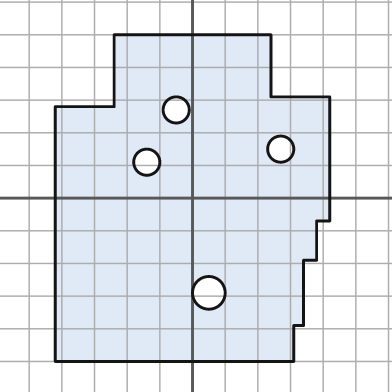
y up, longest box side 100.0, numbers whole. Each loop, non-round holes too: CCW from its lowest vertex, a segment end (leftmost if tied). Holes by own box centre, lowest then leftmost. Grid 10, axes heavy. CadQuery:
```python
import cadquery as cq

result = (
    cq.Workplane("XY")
    .moveTo(-42.0, -50.0)
    .lineTo(31.0, -50.0)
    .lineTo(31.0, -39.0)
    .lineTo(34.0, -39.0)
    .lineTo(34.0, -19.0)
    .lineTo(38.0, -19.0)
    .lineTo(38.0, -7.0)
    .lineTo(42.0, -7.0)
    .lineTo(42.0, 31.0)
    .lineTo(24.0, 31.0)
    .lineTo(24.0, 50.0)
    .lineTo(-24.0, 50.0)
    .lineTo(-24.0, 28.0)
    .lineTo(-42.0, 28.0)
    .close()
    .moveTo(5.0, -29.0)
    .circle(5.0)
    .moveTo(-14.0, 11.0)
    .circle(4.0)
    .moveTo(27.0, 15.0)
    .circle(4.0)
    .moveTo(-5.0, 27.0)
    .circle(4.0)
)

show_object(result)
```